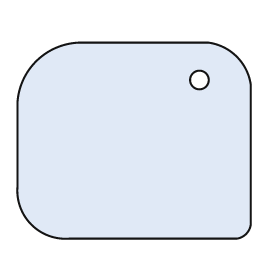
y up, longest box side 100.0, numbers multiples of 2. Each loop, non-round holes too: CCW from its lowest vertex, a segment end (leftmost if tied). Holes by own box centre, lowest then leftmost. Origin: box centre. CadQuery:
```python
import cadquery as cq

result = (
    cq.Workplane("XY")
    .moveTo(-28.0, -42.0)
    .lineTo(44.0, -42.0)
    .threePointArc((48.0, -40.0), (50.0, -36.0))
    .lineTo(50.0, 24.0)
    .threePointArc((44.0, 36.0), (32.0, 42.0))
    .lineTo(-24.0, 42.0)
    .threePointArc((-42.0, 34.0), (-50.0, 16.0))
    .lineTo(-50.0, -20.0)
    .threePointArc((-44.0, -36.0), (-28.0, -42.0))
    .close()
    .moveTo(28.0, 26.0)
    .circle(4.0)
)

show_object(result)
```